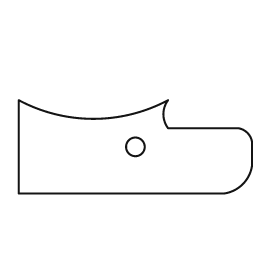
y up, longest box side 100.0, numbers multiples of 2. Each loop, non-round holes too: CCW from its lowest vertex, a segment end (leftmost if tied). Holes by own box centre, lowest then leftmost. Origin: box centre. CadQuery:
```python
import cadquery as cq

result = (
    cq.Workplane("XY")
    .moveTo(-50.0, -20.0)
    .lineTo(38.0, -20.0)
    .threePointArc((46.0, -16.0), (50.0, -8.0))
    .lineTo(50.0, 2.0)
    .threePointArc((48.0, 6.0), (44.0, 8.0))
    .lineTo(14.0, 8.0)
    .threePointArc((12.0, 14.0), (14.0, 20.0))
    .threePointArc((-18.0, 12.0), (-50.0, 20.0))
    .close()
    .moveTo(0.0, 0.0)
    .circle(4.0)
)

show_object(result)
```